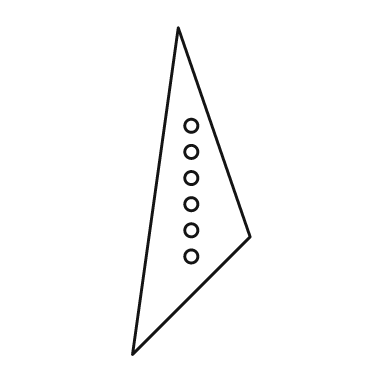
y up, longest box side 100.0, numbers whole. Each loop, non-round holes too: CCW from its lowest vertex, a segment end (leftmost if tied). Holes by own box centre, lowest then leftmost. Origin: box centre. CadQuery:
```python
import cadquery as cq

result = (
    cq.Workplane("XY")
    .moveTo(-18.0, -50.0)
    .lineTo(18.0, -14.0)
    .lineTo(-4.0, 50.0)
    .close()
    .moveTo(0.0, -20.0)
    .circle(2.0)
    .moveTo(0.0, -12.0)
    .circle(2.0)
    .moveTo(0.0, -4.0)
    .circle(2.0)
    .moveTo(0.0, 4.0)
    .circle(2.0)
    .moveTo(0.0, 12.0)
    .circle(2.0)
    .moveTo(0.0, 20.0)
    .circle(2.0)
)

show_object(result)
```